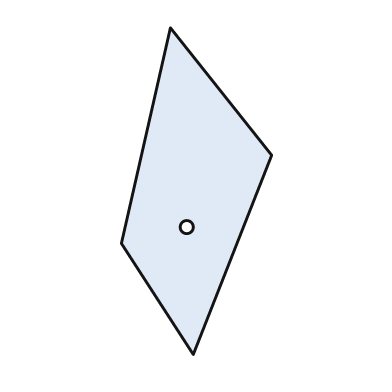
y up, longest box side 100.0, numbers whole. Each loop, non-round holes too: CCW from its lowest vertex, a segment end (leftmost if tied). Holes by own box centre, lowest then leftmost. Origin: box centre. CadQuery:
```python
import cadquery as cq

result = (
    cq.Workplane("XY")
    .moveTo(-1.0, -50.0)
    .lineTo(23.0, 11.0)
    .lineTo(-8.0, 50.0)
    .lineTo(-23.0, -16.0)
    .close()
    .moveTo(-3.0, -11.0)
    .circle(2.0)
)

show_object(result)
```